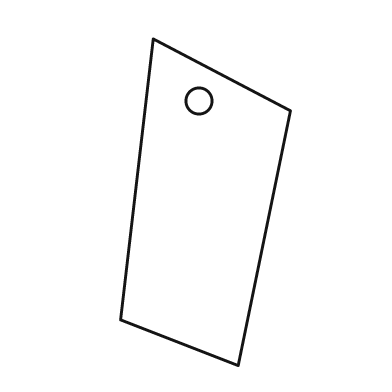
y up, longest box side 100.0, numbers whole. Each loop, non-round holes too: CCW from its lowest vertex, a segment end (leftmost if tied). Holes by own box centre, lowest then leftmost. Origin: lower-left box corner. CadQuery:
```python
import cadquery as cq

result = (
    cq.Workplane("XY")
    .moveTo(36.0, 0.0)
    .lineTo(52.0, 78.0)
    .lineTo(10.0, 100.0)
    .lineTo(0.0, 14.0)
    .close()
    .moveTo(24.0, 81.0)
    .circle(4.0)
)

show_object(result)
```